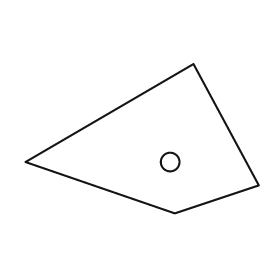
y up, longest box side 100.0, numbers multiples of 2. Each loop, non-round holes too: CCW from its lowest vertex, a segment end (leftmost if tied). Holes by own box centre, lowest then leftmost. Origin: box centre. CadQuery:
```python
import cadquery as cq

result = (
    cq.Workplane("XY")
    .moveTo(14.0, -32.0)
    .lineTo(50.0, -20.0)
    .lineTo(22.0, 32.0)
    .lineTo(-50.0, -10.0)
    .close()
    .moveTo(12.0, -10.0)
    .circle(4.0)
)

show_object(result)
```